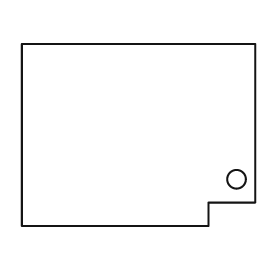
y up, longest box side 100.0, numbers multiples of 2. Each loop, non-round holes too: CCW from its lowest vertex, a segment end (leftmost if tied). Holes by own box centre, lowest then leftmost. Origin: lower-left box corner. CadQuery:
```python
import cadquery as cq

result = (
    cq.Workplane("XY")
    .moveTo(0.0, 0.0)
    .lineTo(80.0, 0.0)
    .lineTo(80.0, 10.0)
    .lineTo(100.0, 10.0)
    .lineTo(100.0, 78.0)
    .lineTo(0.0, 78.0)
    .close()
    .moveTo(92.0, 20.0)
    .circle(4.0)
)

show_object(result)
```